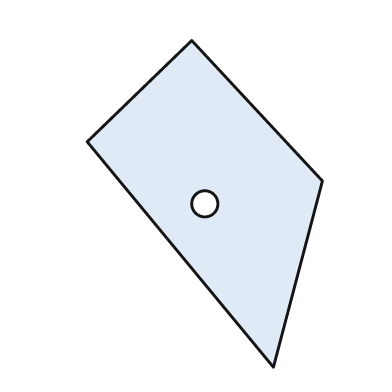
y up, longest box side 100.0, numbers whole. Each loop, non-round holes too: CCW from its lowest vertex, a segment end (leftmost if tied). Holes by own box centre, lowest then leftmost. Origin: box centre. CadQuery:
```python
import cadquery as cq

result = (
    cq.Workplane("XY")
    .moveTo(21.0, -50.0)
    .lineTo(36.0, 7.0)
    .lineTo(-4.0, 50.0)
    .lineTo(-36.0, 19.0)
    .close()
    .moveTo(0.0, 0.0)
    .circle(4.0)
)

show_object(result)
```